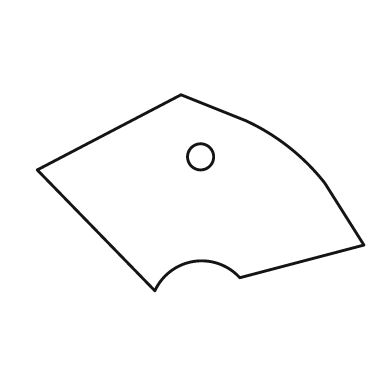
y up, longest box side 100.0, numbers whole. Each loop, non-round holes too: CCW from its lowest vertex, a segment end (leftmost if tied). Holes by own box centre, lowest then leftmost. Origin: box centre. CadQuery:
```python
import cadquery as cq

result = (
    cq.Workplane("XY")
    .moveTo(-14.0, -30.0)
    .threePointArc((-2.0, -21.0), (12.0, -26.0))
    .lineTo(50.0, -16.0)
    .lineTo(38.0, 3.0)
    .threePointArc((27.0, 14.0), (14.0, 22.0))
    .lineTo(-6.0, 30.0)
    .lineTo(-50.0, 7.0)
    .close()
    .moveTo(0.0, 11.0)
    .circle(4.0)
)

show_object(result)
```